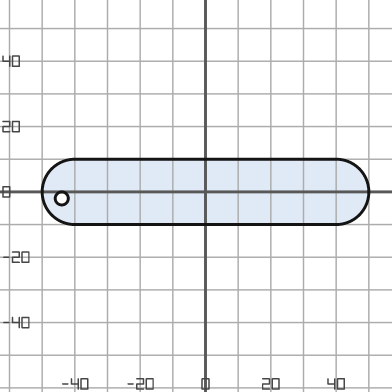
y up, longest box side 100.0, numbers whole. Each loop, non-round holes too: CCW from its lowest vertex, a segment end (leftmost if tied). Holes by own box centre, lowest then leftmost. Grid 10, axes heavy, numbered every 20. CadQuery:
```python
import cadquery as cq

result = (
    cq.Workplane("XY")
    .moveTo(-40.0, -10.0)
    .lineTo(40.0, -10.0)
    .threePointArc((50.0, 0.0), (40.0, 10.0))
    .lineTo(-40.0, 10.0)
    .threePointArc((-50.0, 0.0), (-40.0, -10.0))
    .close()
    .moveTo(-44.0, -2.0)
    .circle(2.0)
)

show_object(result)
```